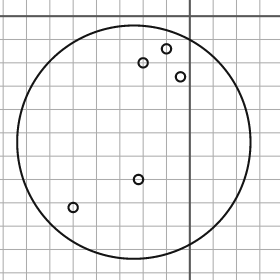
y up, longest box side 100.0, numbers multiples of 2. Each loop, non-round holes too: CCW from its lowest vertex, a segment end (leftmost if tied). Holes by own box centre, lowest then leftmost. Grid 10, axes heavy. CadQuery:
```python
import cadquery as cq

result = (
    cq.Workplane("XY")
    .moveTo(-24.0, -54.0)
    .circle(50.0)
    .moveTo(-50.0, -82.0)
    .circle(2.0)
    .moveTo(-22.0, -70.0)
    .circle(2.0)
    .moveTo(-4.0, -26.0)
    .circle(2.0)
    .moveTo(-20.0, -20.0)
    .circle(2.0)
    .moveTo(-10.0, -14.0)
    .circle(2.0)
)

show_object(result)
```